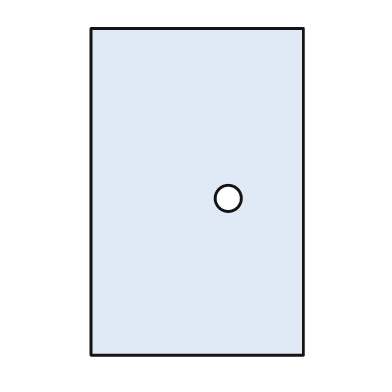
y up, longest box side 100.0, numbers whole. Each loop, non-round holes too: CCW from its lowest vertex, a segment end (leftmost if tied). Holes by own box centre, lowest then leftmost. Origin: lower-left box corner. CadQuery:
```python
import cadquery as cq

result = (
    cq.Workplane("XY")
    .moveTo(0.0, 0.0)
    .lineTo(65.0, 0.0)
    .lineTo(65.0, 100.0)
    .lineTo(0.0, 100.0)
    .close()
    .moveTo(42.0, 48.0)
    .circle(4.0)
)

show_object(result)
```